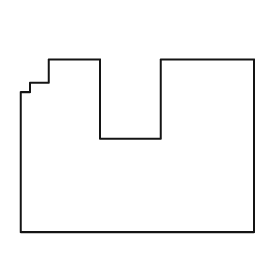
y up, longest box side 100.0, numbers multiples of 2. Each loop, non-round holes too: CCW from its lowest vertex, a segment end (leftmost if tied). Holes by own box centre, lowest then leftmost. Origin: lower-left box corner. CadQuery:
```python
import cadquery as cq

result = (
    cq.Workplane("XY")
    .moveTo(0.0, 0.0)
    .lineTo(100.0, 0.0)
    .lineTo(100.0, 74.0)
    .lineTo(60.0, 74.0)
    .lineTo(60.0, 40.0)
    .lineTo(34.0, 40.0)
    .lineTo(34.0, 74.0)
    .lineTo(12.0, 74.0)
    .lineTo(12.0, 64.0)
    .lineTo(4.0, 64.0)
    .lineTo(4.0, 60.0)
    .lineTo(0.0, 60.0)
    .close()
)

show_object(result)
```